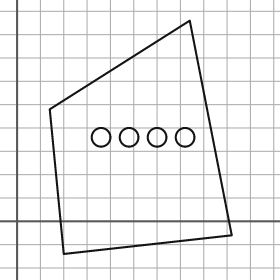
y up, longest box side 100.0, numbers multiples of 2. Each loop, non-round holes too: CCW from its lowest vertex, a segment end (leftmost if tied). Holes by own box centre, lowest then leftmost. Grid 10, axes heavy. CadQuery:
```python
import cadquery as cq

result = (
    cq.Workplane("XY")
    .moveTo(20.0, -14.0)
    .lineTo(92.0, -6.0)
    .lineTo(74.0, 86.0)
    .lineTo(14.0, 48.0)
    .close()
    .moveTo(36.0, 36.0)
    .circle(4.0)
    .moveTo(48.0, 36.0)
    .circle(4.0)
    .moveTo(60.0, 36.0)
    .circle(4.0)
    .moveTo(72.0, 36.0)
    .circle(4.0)
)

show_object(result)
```